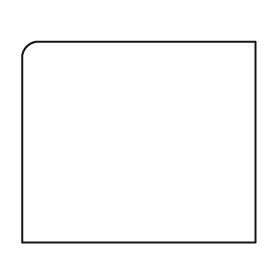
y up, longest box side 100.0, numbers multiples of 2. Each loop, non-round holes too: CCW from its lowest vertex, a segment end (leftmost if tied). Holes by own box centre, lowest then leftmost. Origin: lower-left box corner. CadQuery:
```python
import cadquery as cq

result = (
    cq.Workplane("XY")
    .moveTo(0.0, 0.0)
    .lineTo(100.0, 0.0)
    .lineTo(100.0, 86.0)
    .lineTo(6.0, 86.0)
    .threePointArc((2.0, 84.0), (0.0, 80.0))
    .close()
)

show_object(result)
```